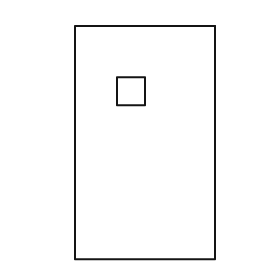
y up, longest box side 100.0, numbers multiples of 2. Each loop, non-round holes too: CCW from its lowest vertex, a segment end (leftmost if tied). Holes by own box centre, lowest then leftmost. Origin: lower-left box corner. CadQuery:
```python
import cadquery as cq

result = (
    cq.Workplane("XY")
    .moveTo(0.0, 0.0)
    .lineTo(60.0, 0.0)
    .lineTo(60.0, 100.0)
    .lineTo(0.0, 100.0)
    .close()
    .moveTo(18.0, 66.0)
    .lineTo(30.0, 66.0)
    .lineTo(30.0, 78.0)
    .lineTo(18.0, 78.0)
    .close()
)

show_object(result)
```